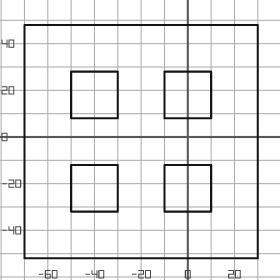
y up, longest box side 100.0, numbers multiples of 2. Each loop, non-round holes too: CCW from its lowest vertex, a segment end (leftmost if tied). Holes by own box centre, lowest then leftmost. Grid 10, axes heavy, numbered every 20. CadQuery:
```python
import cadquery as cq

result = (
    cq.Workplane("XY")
    .moveTo(-70.0, -52.0)
    .lineTo(30.0, -52.0)
    .lineTo(30.0, 48.0)
    .lineTo(-70.0, 48.0)
    .close()
    .moveTo(-50.0, -32.0)
    .lineTo(-30.0, -32.0)
    .lineTo(-30.0, -12.0)
    .lineTo(-50.0, -12.0)
    .close()
    .moveTo(-10.0, -32.0)
    .lineTo(10.0, -32.0)
    .lineTo(10.0, -12.0)
    .lineTo(-10.0, -12.0)
    .close()
    .moveTo(-50.0, 8.0)
    .lineTo(-30.0, 8.0)
    .lineTo(-30.0, 28.0)
    .lineTo(-50.0, 28.0)
    .close()
    .moveTo(-10.0, 8.0)
    .lineTo(10.0, 8.0)
    .lineTo(10.0, 28.0)
    .lineTo(-10.0, 28.0)
    .close()
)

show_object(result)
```